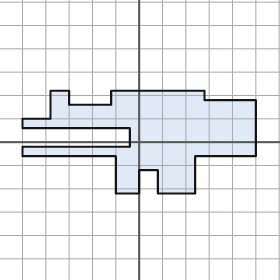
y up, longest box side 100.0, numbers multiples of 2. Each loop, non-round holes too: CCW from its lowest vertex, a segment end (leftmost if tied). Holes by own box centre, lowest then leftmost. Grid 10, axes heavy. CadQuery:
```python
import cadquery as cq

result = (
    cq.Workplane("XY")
    .moveTo(-10.0, -22.0)
    .lineTo(0.0, -22.0)
    .lineTo(0.0, -12.0)
    .lineTo(8.0, -12.0)
    .lineTo(8.0, -22.0)
    .lineTo(24.0, -22.0)
    .lineTo(24.0, -6.0)
    .lineTo(50.0, -6.0)
    .lineTo(50.0, 18.0)
    .lineTo(28.0, 18.0)
    .lineTo(28.0, 22.0)
    .lineTo(-12.0, 22.0)
    .lineTo(-12.0, 16.0)
    .lineTo(-30.0, 16.0)
    .lineTo(-30.0, 22.0)
    .lineTo(-38.0, 22.0)
    .lineTo(-38.0, 10.0)
    .lineTo(-50.0, 10.0)
    .lineTo(-50.0, 6.0)
    .lineTo(-4.0, 6.0)
    .lineTo(-4.0, -2.0)
    .lineTo(-50.0, -2.0)
    .lineTo(-50.0, -6.0)
    .lineTo(-10.0, -6.0)
    .close()
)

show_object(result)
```